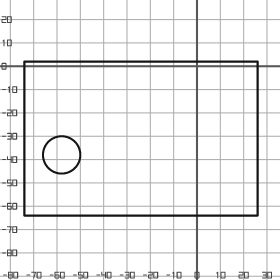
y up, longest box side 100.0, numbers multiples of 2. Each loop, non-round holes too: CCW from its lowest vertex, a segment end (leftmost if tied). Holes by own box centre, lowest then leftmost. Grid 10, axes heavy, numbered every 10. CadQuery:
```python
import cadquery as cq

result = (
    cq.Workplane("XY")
    .moveTo(-74.0, -64.0)
    .lineTo(26.0, -64.0)
    .lineTo(26.0, 2.0)
    .lineTo(-74.0, 2.0)
    .close()
    .moveTo(-58.0, -38.0)
    .circle(8.0)
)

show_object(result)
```